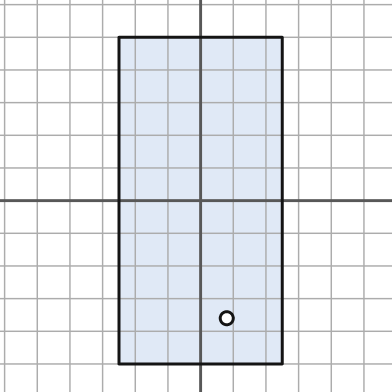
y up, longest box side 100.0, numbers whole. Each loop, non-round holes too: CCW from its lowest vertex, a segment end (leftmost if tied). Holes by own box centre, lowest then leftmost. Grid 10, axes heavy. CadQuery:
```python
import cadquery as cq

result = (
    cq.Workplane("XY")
    .moveTo(-25.0, -50.0)
    .lineTo(25.0, -50.0)
    .lineTo(25.0, 50.0)
    .lineTo(-25.0, 50.0)
    .close()
    .moveTo(8.0, -36.0)
    .circle(2.0)
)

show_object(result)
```